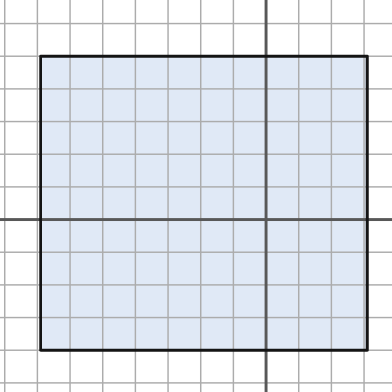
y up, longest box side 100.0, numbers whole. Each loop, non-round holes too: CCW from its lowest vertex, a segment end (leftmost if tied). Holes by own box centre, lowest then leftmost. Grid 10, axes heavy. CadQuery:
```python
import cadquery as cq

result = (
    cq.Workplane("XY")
    .moveTo(-69.0, -40.0)
    .lineTo(31.0, -40.0)
    .lineTo(31.0, 50.0)
    .lineTo(-69.0, 50.0)
    .close()
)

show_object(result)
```